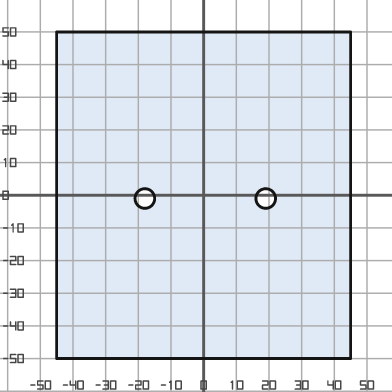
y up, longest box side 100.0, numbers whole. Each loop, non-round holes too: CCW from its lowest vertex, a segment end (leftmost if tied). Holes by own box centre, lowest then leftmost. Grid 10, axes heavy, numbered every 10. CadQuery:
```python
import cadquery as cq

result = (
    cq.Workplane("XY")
    .moveTo(-45.0, -50.0)
    .lineTo(45.0, -50.0)
    .lineTo(45.0, 50.0)
    .lineTo(-45.0, 50.0)
    .close()
    .moveTo(-18.0, -1.0)
    .circle(3.0)
    .moveTo(19.0, -1.0)
    .circle(3.0)
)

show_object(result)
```